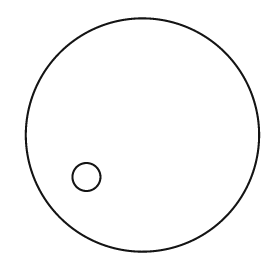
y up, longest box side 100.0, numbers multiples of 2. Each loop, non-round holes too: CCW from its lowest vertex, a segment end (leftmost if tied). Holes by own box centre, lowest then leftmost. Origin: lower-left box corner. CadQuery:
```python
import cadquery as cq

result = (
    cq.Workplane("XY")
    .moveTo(50.0, 50.0)
    .circle(50.0)
    .moveTo(26.0, 32.0)
    .circle(6.0)
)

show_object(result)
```